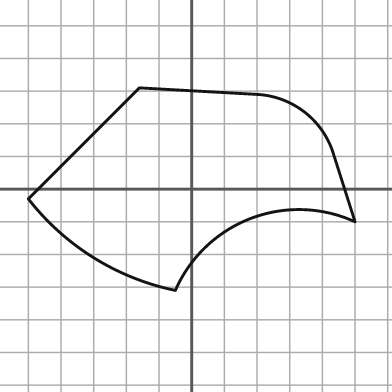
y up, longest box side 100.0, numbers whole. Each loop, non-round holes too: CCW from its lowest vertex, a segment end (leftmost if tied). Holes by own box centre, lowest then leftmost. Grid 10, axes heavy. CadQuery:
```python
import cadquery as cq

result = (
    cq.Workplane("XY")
    .moveTo(-5.0, -31.0)
    .threePointArc((18.0, -9.0), (50.0, -10.0))
    .lineTo(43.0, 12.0)
    .threePointArc((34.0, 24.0), (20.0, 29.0))
    .lineTo(-16.0, 31.0)
    .lineTo(-50.0, -3.0)
    .threePointArc((-30.0, -21.0), (-5.0, -31.0))
    .close()
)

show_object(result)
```